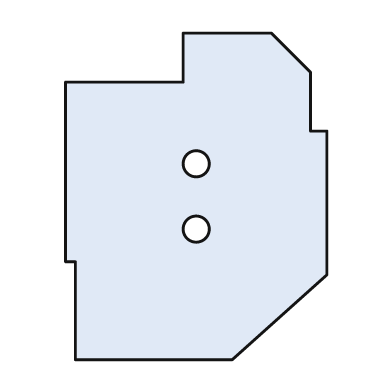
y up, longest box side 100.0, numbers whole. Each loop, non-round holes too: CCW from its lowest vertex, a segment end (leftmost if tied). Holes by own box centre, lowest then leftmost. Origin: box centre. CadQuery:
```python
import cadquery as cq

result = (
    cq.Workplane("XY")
    .moveTo(-37.0, -50.0)
    .lineTo(11.0, -50.0)
    .lineTo(40.0, -24.0)
    .lineTo(40.0, 20.0)
    .lineTo(35.0, 20.0)
    .lineTo(35.0, 38.0)
    .lineTo(23.0, 50.0)
    .lineTo(-4.0, 50.0)
    .lineTo(-4.0, 35.0)
    .lineTo(-40.0, 35.0)
    .lineTo(-40.0, -20.0)
    .lineTo(-37.0, -20.0)
    .close()
    .moveTo(0.0, -10.0)
    .circle(4.0)
    .moveTo(0.0, 10.0)
    .circle(4.0)
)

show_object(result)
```